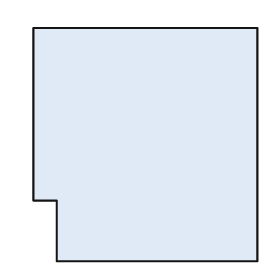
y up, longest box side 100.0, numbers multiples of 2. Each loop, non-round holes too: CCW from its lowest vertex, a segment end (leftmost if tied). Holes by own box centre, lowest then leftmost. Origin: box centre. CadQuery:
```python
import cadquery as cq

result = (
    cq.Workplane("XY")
    .moveTo(-38.0, -50.0)
    .lineTo(48.0, -50.0)
    .lineTo(48.0, 50.0)
    .lineTo(-48.0, 50.0)
    .lineTo(-48.0, -24.0)
    .lineTo(-38.0, -24.0)
    .close()
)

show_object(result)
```